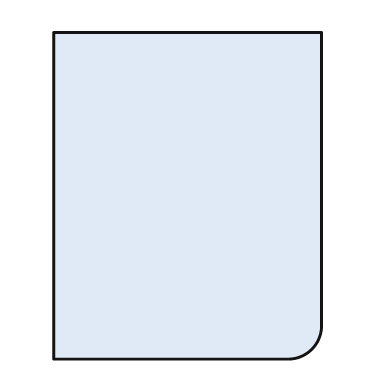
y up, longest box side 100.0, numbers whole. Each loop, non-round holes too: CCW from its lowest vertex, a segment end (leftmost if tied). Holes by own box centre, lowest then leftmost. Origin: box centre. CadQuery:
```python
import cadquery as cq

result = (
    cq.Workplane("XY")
    .moveTo(-41.0, -50.0)
    .lineTo(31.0, -50.0)
    .threePointArc((38.0, -47.0), (41.0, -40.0))
    .lineTo(41.0, 50.0)
    .lineTo(-41.0, 50.0)
    .close()
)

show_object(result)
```